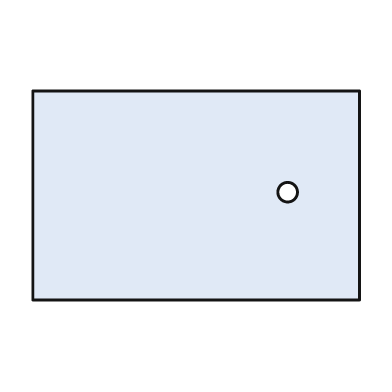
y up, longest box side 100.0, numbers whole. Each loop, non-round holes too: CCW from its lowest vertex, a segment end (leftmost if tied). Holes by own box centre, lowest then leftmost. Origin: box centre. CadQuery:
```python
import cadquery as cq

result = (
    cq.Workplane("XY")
    .moveTo(-50.0, -32.0)
    .lineTo(50.0, -32.0)
    .lineTo(50.0, 32.0)
    .lineTo(-50.0, 32.0)
    .close()
    .moveTo(28.0, 1.0)
    .circle(3.0)
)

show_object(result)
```